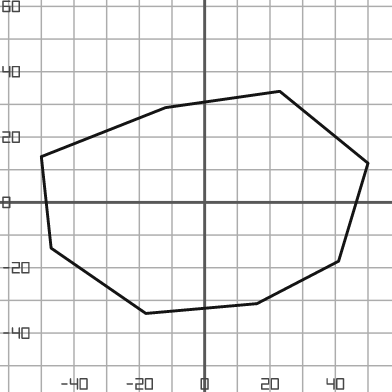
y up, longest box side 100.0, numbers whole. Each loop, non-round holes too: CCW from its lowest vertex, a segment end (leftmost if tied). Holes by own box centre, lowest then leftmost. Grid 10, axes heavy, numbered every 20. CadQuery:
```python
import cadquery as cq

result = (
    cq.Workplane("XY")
    .moveTo(-18.0, -34.0)
    .lineTo(16.0, -31.0)
    .lineTo(41.0, -18.0)
    .lineTo(50.0, 12.0)
    .lineTo(23.0, 34.0)
    .lineTo(-12.0, 29.0)
    .lineTo(-50.0, 14.0)
    .lineTo(-47.0, -14.0)
    .close()
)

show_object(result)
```